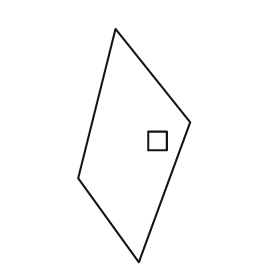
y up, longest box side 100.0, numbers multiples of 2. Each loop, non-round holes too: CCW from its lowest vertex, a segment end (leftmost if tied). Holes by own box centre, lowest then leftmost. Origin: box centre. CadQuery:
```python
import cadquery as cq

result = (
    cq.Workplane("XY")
    .moveTo(2.0, -50.0)
    .lineTo(24.0, 10.0)
    .lineTo(-8.0, 50.0)
    .lineTo(-24.0, -14.0)
    .close()
    .moveTo(6.0, -2.0)
    .lineTo(14.0, -2.0)
    .lineTo(14.0, 6.0)
    .lineTo(6.0, 6.0)
    .close()
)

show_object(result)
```